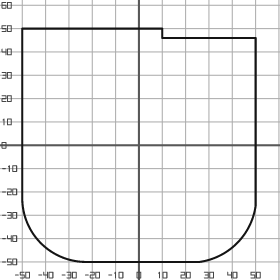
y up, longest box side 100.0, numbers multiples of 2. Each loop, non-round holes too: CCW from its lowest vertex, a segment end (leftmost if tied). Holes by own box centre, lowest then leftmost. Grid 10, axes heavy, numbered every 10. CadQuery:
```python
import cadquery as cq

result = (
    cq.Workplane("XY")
    .moveTo(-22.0, -50.0)
    .lineTo(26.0, -50.0)
    .threePointArc((42.0, -42.0), (50.0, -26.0))
    .lineTo(50.0, 46.0)
    .lineTo(10.0, 46.0)
    .lineTo(10.0, 50.0)
    .lineTo(-50.0, 50.0)
    .lineTo(-50.0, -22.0)
    .threePointArc((-42.0, -42.0), (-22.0, -50.0))
    .close()
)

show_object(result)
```